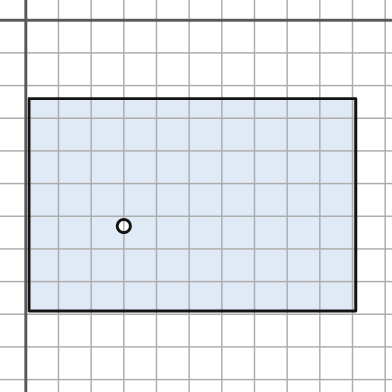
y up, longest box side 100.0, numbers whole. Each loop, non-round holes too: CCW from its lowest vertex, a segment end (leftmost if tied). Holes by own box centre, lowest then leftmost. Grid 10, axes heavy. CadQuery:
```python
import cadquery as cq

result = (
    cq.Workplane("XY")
    .moveTo(1.0, -89.0)
    .lineTo(101.0, -89.0)
    .lineTo(101.0, -24.0)
    .lineTo(1.0, -24.0)
    .close()
    .moveTo(30.0, -63.0)
    .circle(2.0)
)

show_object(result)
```